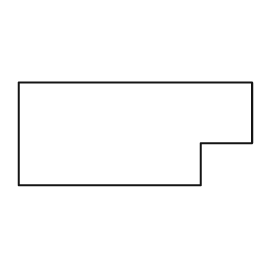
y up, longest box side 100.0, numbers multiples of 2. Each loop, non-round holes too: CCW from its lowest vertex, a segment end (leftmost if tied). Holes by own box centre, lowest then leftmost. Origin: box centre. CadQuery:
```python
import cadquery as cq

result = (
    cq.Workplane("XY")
    .moveTo(-50.0, -22.0)
    .lineTo(28.0, -22.0)
    .lineTo(28.0, -4.0)
    .lineTo(50.0, -4.0)
    .lineTo(50.0, 22.0)
    .lineTo(-50.0, 22.0)
    .close()
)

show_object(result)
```